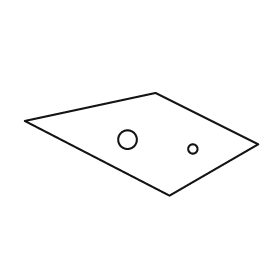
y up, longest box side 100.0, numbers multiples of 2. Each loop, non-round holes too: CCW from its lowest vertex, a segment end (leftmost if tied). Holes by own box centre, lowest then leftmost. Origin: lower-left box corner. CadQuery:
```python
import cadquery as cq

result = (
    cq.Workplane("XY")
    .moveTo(62.0, 0.0)
    .lineTo(100.0, 22.0)
    .lineTo(56.0, 44.0)
    .lineTo(0.0, 32.0)
    .close()
    .moveTo(72.0, 20.0)
    .circle(2.0)
    .moveTo(44.0, 24.0)
    .circle(4.0)
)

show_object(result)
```